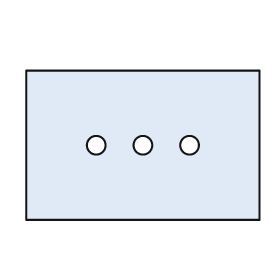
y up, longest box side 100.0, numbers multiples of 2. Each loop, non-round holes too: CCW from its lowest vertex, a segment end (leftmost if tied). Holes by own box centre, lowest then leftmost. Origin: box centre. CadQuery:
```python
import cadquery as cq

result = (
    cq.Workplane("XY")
    .moveTo(-50.0, -32.0)
    .lineTo(50.0, -32.0)
    .lineTo(50.0, 32.0)
    .lineTo(-50.0, 32.0)
    .close()
    .moveTo(-20.0, 0.0)
    .circle(4.0)
    .moveTo(0.0, 0.0)
    .circle(4.0)
    .moveTo(20.0, 0.0)
    .circle(4.0)
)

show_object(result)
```